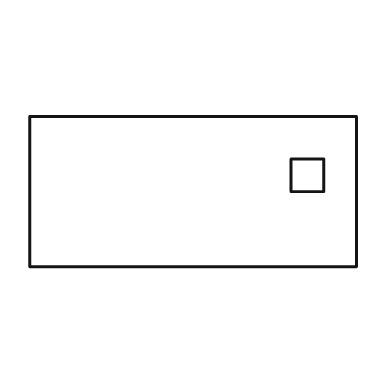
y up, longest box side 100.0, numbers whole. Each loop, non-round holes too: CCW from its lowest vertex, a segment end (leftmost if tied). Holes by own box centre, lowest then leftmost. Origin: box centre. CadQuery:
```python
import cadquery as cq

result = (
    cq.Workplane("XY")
    .moveTo(-50.0, -23.0)
    .lineTo(50.0, -23.0)
    .lineTo(50.0, 23.0)
    .lineTo(-50.0, 23.0)
    .close()
    .moveTo(30.0, 0.0)
    .lineTo(40.0, 0.0)
    .lineTo(40.0, 10.0)
    .lineTo(30.0, 10.0)
    .close()
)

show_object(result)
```